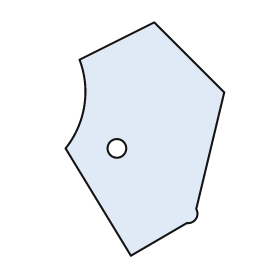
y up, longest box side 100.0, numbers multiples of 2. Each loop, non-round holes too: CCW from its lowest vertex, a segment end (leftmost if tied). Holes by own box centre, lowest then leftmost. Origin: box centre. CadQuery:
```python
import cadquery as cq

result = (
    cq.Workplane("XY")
    .moveTo(-6.0, -50.0)
    .lineTo(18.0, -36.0)
    .threePointArc((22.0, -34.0), (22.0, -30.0))
    .lineTo(34.0, 20.0)
    .lineTo(4.0, 50.0)
    .lineTo(-28.0, 34.0)
    .threePointArc((-26.0, 14.0), (-34.0, -4.0))
    .close()
    .moveTo(-12.0, -4.0)
    .circle(4.0)
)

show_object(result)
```